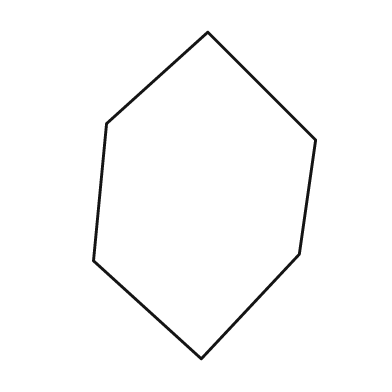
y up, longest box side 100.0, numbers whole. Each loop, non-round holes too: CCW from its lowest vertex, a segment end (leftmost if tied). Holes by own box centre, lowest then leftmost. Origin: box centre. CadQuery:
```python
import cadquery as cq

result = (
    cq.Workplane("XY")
    .moveTo(-1.0, -50.0)
    .lineTo(29.0, -18.0)
    .lineTo(34.0, 17.0)
    .lineTo(1.0, 50.0)
    .lineTo(-30.0, 22.0)
    .lineTo(-34.0, -20.0)
    .close()
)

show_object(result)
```